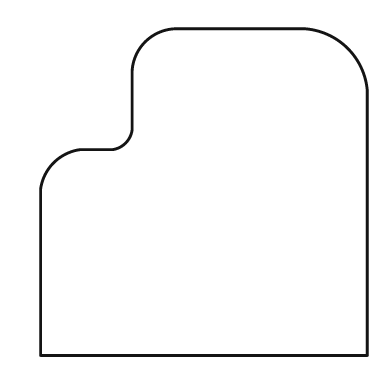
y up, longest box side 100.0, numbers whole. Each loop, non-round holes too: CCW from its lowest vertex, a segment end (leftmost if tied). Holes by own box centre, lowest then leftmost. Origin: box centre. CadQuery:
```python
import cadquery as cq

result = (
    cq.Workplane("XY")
    .moveTo(-50.0, -50.0)
    .lineTo(50.0, -50.0)
    .lineTo(50.0, 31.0)
    .threePointArc((44.0, 44.0), (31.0, 50.0))
    .lineTo(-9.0, 50.0)
    .threePointArc((-18.0, 46.0), (-22.0, 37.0))
    .lineTo(-22.0, 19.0)
    .threePointArc((-24.0, 15.0), (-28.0, 13.0))
    .lineTo(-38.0, 13.0)
    .threePointArc((-46.0, 9.0), (-50.0, 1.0))
    .close()
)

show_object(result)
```